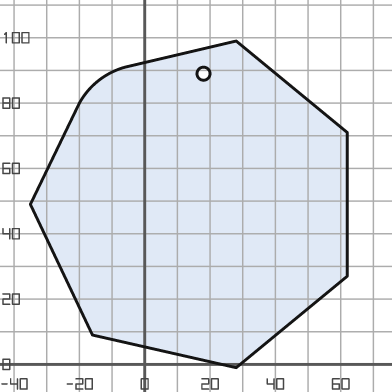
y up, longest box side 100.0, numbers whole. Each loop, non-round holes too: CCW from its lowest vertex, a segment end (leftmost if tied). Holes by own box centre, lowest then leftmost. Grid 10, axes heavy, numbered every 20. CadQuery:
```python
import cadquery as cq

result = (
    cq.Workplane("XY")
    .moveTo(28.0, -1.0)
    .lineTo(62.0, 27.0)
    .lineTo(62.0, 71.0)
    .lineTo(28.0, 99.0)
    .lineTo(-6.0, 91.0)
    .threePointArc((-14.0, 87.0), (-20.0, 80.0))
    .lineTo(-35.0, 49.0)
    .lineTo(-16.0, 9.0)
    .close()
    .moveTo(18.0, 89.0)
    .circle(2.0)
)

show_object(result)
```